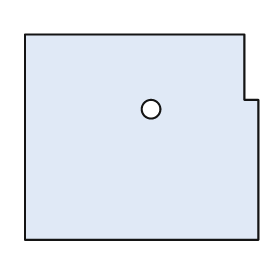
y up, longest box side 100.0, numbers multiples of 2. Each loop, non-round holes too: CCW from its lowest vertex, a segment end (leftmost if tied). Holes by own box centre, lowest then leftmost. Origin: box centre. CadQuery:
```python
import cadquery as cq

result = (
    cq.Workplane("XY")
    .moveTo(-50.0, -44.0)
    .lineTo(50.0, -44.0)
    .lineTo(50.0, 16.0)
    .lineTo(44.0, 16.0)
    .lineTo(44.0, 44.0)
    .lineTo(-50.0, 44.0)
    .close()
    .moveTo(4.0, 12.0)
    .circle(4.0)
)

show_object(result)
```